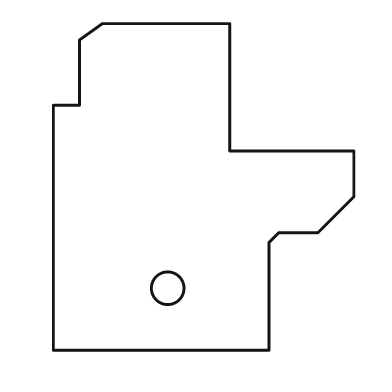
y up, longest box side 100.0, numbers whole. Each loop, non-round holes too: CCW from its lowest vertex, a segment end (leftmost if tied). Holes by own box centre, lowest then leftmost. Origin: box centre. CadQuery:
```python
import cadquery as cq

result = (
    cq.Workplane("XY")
    .moveTo(-46.0, -50.0)
    .lineTo(20.0, -50.0)
    .lineTo(20.0, -17.0)
    .lineTo(23.0, -14.0)
    .lineTo(35.0, -14.0)
    .lineTo(46.0, -3.0)
    .lineTo(46.0, 11.0)
    .lineTo(8.0, 11.0)
    .lineTo(8.0, 50.0)
    .lineTo(-31.0, 50.0)
    .lineTo(-38.0, 45.0)
    .lineTo(-38.0, 25.0)
    .lineTo(-46.0, 25.0)
    .close()
    .moveTo(-11.0, -31.0)
    .circle(5.0)
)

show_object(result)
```